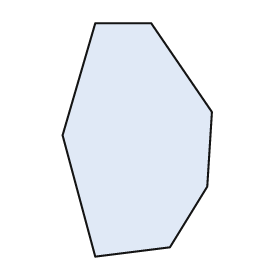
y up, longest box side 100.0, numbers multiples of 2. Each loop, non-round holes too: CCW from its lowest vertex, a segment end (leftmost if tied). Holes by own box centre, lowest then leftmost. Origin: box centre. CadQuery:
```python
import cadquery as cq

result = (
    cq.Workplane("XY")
    .moveTo(-18.0, -50.0)
    .lineTo(14.0, -46.0)
    .lineTo(30.0, -20.0)
    .lineTo(32.0, 12.0)
    .lineTo(6.0, 50.0)
    .lineTo(-18.0, 50.0)
    .lineTo(-32.0, 2.0)
    .close()
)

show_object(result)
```